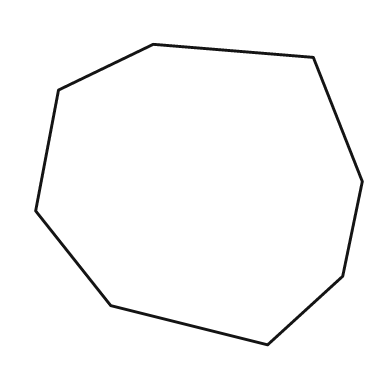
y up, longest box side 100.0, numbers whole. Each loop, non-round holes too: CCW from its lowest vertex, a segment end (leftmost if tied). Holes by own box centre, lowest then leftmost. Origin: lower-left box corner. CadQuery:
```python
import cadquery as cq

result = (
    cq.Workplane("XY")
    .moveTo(71.0, 0.0)
    .lineTo(94.0, 21.0)
    .lineTo(100.0, 50.0)
    .lineTo(85.0, 88.0)
    .lineTo(36.0, 92.0)
    .lineTo(7.0, 78.0)
    .lineTo(0.0, 41.0)
    .lineTo(23.0, 12.0)
    .close()
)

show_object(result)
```